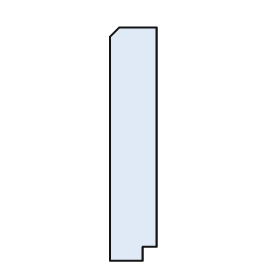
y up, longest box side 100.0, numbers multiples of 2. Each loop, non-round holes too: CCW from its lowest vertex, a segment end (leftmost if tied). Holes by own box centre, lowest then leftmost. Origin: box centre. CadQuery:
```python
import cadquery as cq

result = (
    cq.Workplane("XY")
    .moveTo(-10.0, -50.0)
    .lineTo(4.0, -50.0)
    .lineTo(4.0, -44.0)
    .lineTo(10.0, -44.0)
    .lineTo(10.0, 50.0)
    .lineTo(-6.0, 50.0)
    .lineTo(-10.0, 46.0)
    .close()
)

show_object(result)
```